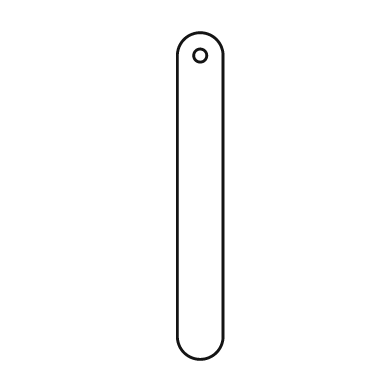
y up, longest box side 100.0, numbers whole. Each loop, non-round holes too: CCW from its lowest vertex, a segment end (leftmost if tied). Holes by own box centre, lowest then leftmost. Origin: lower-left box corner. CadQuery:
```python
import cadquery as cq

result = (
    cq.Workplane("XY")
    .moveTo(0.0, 7.0)
    .threePointArc((7.0, 0.0), (14.0, 7.0))
    .lineTo(14.0, 93.0)
    .threePointArc((7.0, 100.0), (0.0, 93.0))
    .close()
    .moveTo(7.0, 93.0)
    .circle(2.0)
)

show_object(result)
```